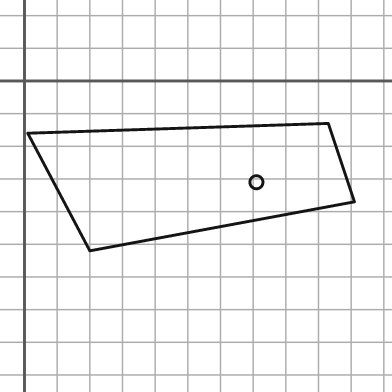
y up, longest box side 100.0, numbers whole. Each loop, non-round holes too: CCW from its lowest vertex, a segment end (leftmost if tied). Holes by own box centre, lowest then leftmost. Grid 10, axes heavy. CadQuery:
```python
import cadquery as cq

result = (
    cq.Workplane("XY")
    .moveTo(20.0, -52.0)
    .lineTo(101.0, -37.0)
    .lineTo(93.0, -13.0)
    .lineTo(1.0, -16.0)
    .close()
    .moveTo(71.0, -31.0)
    .circle(2.0)
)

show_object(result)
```